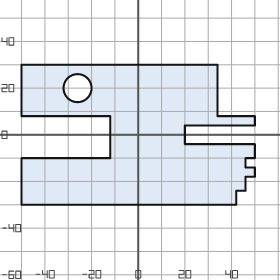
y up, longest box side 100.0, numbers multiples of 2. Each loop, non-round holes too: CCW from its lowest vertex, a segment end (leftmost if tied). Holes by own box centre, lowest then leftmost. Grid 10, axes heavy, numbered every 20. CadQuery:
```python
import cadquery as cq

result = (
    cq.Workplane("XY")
    .moveTo(-50.0, -30.0)
    .lineTo(42.0, -30.0)
    .lineTo(42.0, -24.0)
    .lineTo(46.0, -24.0)
    .lineTo(46.0, -18.0)
    .lineTo(50.0, -18.0)
    .lineTo(50.0, -14.0)
    .lineTo(46.0, -14.0)
    .lineTo(46.0, -10.0)
    .lineTo(50.0, -10.0)
    .lineTo(50.0, -4.0)
    .lineTo(20.0, -4.0)
    .lineTo(20.0, 4.0)
    .lineTo(50.0, 4.0)
    .lineTo(50.0, 8.0)
    .lineTo(34.0, 8.0)
    .lineTo(34.0, 30.0)
    .lineTo(-50.0, 30.0)
    .lineTo(-50.0, 8.0)
    .lineTo(-12.0, 8.0)
    .lineTo(-12.0, -10.0)
    .lineTo(-50.0, -10.0)
    .close()
    .moveTo(-26.0, 20.0)
    .circle(6.0)
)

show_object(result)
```